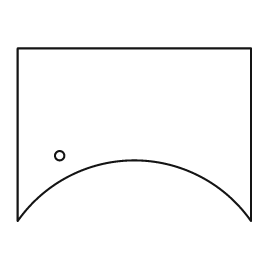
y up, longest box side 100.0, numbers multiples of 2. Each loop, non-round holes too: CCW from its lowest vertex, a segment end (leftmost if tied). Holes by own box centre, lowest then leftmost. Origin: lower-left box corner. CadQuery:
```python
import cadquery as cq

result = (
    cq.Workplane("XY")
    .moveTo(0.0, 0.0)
    .threePointArc((50.0, 26.0), (100.0, 0.0))
    .lineTo(100.0, 74.0)
    .lineTo(0.0, 74.0)
    .close()
    .moveTo(18.0, 28.0)
    .circle(2.0)
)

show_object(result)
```